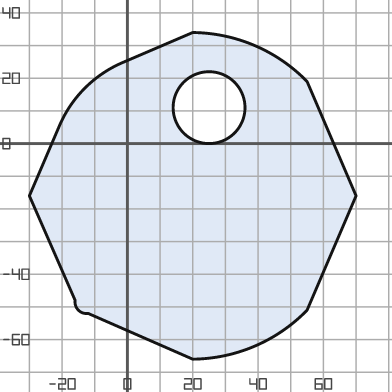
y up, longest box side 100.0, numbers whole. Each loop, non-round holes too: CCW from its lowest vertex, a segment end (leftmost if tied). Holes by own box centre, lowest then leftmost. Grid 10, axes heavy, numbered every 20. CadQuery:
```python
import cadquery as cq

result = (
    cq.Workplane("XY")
    .moveTo(20.0, -66.0)
    .threePointArc((39.0, -62.0), (55.0, -51.0))
    .lineTo(70.0, -16.0)
    .lineTo(55.0, 19.0)
    .threePointArc((39.0, 30.0), (20.0, 34.0))
    .lineTo(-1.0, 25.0)
    .threePointArc((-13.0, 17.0), (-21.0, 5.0))
    .lineTo(-30.0, -16.0)
    .lineTo(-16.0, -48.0)
    .threePointArc((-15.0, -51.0), (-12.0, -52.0))
    .close()
    .moveTo(25.0, 11.0)
    .circle(11.0)
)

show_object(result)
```